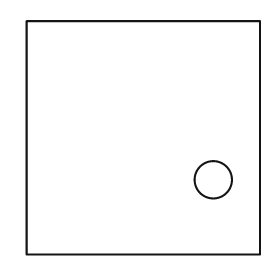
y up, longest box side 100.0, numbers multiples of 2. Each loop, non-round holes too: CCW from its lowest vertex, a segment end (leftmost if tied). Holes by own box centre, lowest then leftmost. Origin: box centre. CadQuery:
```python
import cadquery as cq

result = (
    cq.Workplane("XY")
    .moveTo(-50.0, -50.0)
    .lineTo(50.0, -50.0)
    .lineTo(50.0, 50.0)
    .lineTo(-50.0, 50.0)
    .close()
    .moveTo(30.0, -18.0)
    .circle(8.0)
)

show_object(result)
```